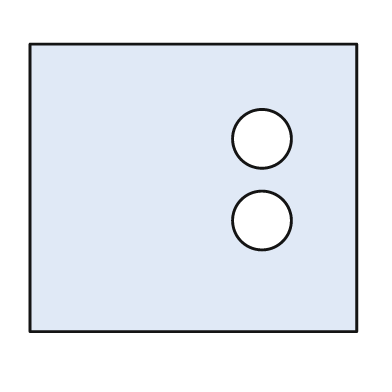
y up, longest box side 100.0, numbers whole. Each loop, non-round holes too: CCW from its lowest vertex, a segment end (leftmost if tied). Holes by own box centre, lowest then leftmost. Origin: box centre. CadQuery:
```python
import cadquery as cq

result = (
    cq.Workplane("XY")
    .moveTo(-50.0, -44.0)
    .lineTo(50.0, -44.0)
    .lineTo(50.0, 44.0)
    .lineTo(-50.0, 44.0)
    .close()
    .moveTo(21.0, -10.0)
    .circle(9.0)
    .moveTo(21.0, 15.0)
    .circle(9.0)
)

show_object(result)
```